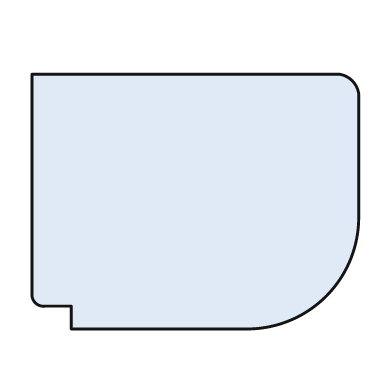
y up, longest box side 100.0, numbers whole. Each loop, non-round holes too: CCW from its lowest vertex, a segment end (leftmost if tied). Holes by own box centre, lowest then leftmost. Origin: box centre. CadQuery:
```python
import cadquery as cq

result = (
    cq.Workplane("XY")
    .moveTo(-38.0, -39.0)
    .lineTo(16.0, -39.0)
    .threePointArc((40.0, -29.0), (50.0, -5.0))
    .lineTo(50.0, 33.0)
    .threePointArc((48.0, 37.0), (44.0, 39.0))
    .lineTo(-50.0, 39.0)
    .lineTo(-50.0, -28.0)
    .threePointArc((-49.0, -31.0), (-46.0, -32.0))
    .lineTo(-38.0, -32.0)
    .close()
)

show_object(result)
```